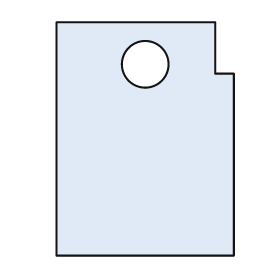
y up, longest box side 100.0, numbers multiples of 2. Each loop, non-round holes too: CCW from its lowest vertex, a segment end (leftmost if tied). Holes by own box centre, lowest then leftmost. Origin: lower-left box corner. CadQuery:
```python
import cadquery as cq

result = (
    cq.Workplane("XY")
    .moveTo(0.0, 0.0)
    .lineTo(76.0, 0.0)
    .lineTo(76.0, 78.0)
    .lineTo(68.0, 78.0)
    .lineTo(68.0, 100.0)
    .lineTo(0.0, 100.0)
    .close()
    .moveTo(38.0, 82.0)
    .circle(10.0)
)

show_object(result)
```